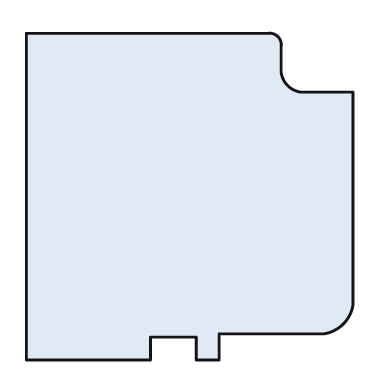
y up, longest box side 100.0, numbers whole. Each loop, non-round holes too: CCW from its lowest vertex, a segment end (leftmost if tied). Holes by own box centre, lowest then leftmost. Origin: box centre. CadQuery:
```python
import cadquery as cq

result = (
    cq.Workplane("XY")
    .moveTo(-50.0, -50.0)
    .lineTo(-12.0, -50.0)
    .lineTo(-12.0, -43.0)
    .lineTo(2.0, -43.0)
    .lineTo(2.0, -50.0)
    .lineTo(9.0, -50.0)
    .lineTo(9.0, -42.0)
    .lineTo(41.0, -42.0)
    .threePointArc((47.0, -39.0), (50.0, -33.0))
    .lineTo(50.0, 32.0)
    .lineTo(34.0, 32.0)
    .threePointArc((30.0, 34.0), (28.0, 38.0))
    .lineTo(28.0, 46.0)
    .threePointArc((27.0, 49.0), (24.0, 50.0))
    .lineTo(-50.0, 50.0)
    .close()
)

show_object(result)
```